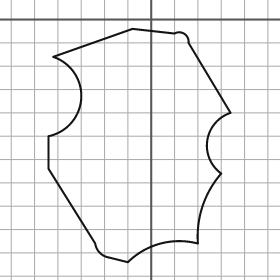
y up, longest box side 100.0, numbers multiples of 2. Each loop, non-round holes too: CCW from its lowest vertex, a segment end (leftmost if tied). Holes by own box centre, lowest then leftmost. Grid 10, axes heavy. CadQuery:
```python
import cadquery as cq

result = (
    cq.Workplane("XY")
    .moveTo(-10.0, -104.0)
    .threePointArc((4.0, -96.0), (20.0, -96.0))
    .threePointArc((22.0, -80.0), (30.0, -66.0))
    .threePointArc((24.0, -52.0), (34.0, -40.0))
    .lineTo(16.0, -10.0)
    .threePointArc((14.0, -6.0), (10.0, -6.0))
    .lineTo(-8.0, -4.0)
    .lineTo(-42.0, -16.0)
    .threePointArc((-30.0, -34.0), (-44.0, -50.0))
    .lineTo(-44.0, -64.0)
    .lineTo(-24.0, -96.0)
    .threePointArc((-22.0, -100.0), (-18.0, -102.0))
    .close()
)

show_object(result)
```